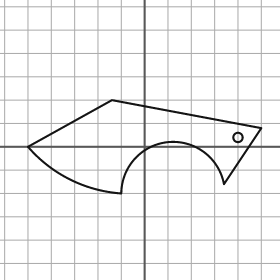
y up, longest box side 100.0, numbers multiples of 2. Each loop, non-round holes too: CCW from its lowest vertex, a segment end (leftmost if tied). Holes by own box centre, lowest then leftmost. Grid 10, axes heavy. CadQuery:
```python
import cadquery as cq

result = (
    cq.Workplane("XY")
    .moveTo(-10.0, -20.0)
    .threePointArc((10.0, 2.0), (34.0, -16.0))
    .lineTo(50.0, 8.0)
    .lineTo(-14.0, 20.0)
    .lineTo(-50.0, 0.0)
    .threePointArc((-32.0, -14.0), (-10.0, -20.0))
    .close()
    .moveTo(40.0, 4.0)
    .circle(2.0)
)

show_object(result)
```